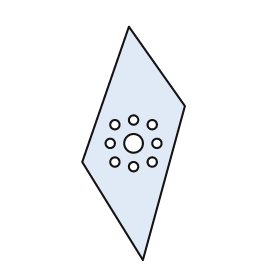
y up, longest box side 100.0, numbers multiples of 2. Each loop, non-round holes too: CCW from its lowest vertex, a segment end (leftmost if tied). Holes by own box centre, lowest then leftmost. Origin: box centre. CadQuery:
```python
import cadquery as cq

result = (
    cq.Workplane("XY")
    .moveTo(4.0, -50.0)
    .lineTo(22.0, 16.0)
    .lineTo(-2.0, 50.0)
    .lineTo(-22.0, -8.0)
    .close()
    .moveTo(0.0, -10.0)
    .circle(2.0)
    .moveTo(-8.0, -8.0)
    .circle(2.0)
    .moveTo(8.0, -8.0)
    .circle(2.0)
    .moveTo(-10.0, 0.0)
    .circle(2.0)
    .moveTo(0.0, 0.0)
    .circle(4.0)
    .moveTo(10.0, 0.0)
    .circle(2.0)
    .moveTo(-8.0, 8.0)
    .circle(2.0)
    .moveTo(8.0, 8.0)
    .circle(2.0)
    .moveTo(0.0, 10.0)
    .circle(2.0)
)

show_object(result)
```